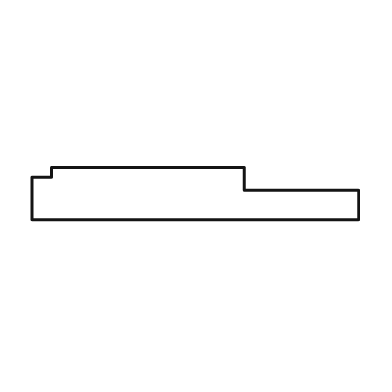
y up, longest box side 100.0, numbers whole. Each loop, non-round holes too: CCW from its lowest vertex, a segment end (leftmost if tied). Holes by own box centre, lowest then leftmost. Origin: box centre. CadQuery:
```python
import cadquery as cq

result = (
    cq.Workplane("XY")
    .moveTo(-50.0, -8.0)
    .lineTo(50.0, -8.0)
    .lineTo(50.0, 1.0)
    .lineTo(15.0, 1.0)
    .lineTo(15.0, 8.0)
    .lineTo(-44.0, 8.0)
    .lineTo(-44.0, 5.0)
    .lineTo(-50.0, 5.0)
    .close()
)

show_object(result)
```